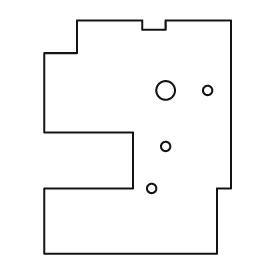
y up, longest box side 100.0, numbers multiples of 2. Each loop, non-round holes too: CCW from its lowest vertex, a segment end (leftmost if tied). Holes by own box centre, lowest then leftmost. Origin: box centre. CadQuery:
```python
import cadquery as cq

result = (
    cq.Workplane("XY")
    .moveTo(-40.0, -50.0)
    .lineTo(34.0, -50.0)
    .lineTo(34.0, -22.0)
    .lineTo(40.0, -22.0)
    .lineTo(40.0, 50.0)
    .lineTo(12.0, 50.0)
    .lineTo(12.0, 46.0)
    .lineTo(2.0, 46.0)
    .lineTo(2.0, 50.0)
    .lineTo(-26.0, 50.0)
    .lineTo(-26.0, 36.0)
    .lineTo(-40.0, 36.0)
    .lineTo(-40.0, 2.0)
    .lineTo(-2.0, 2.0)
    .lineTo(-2.0, -22.0)
    .lineTo(-40.0, -22.0)
    .close()
    .moveTo(6.0, -22.0)
    .circle(2.0)
    .moveTo(12.0, -4.0)
    .circle(2.0)
    .moveTo(12.0, 20.0)
    .circle(4.0)
    .moveTo(30.0, 20.0)
    .circle(2.0)
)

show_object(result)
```